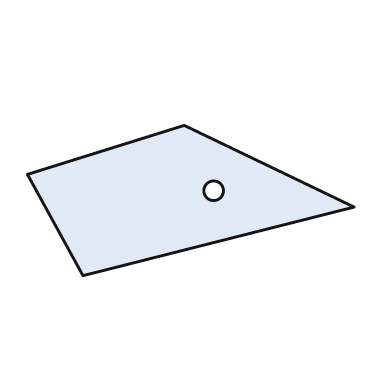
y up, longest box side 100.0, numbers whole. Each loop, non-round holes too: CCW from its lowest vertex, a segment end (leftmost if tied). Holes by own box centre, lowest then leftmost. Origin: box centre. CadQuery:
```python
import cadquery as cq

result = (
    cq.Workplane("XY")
    .moveTo(-33.0, -23.0)
    .lineTo(50.0, -2.0)
    .lineTo(-2.0, 23.0)
    .lineTo(-50.0, 8.0)
    .close()
    .moveTo(7.0, 3.0)
    .circle(3.0)
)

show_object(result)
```